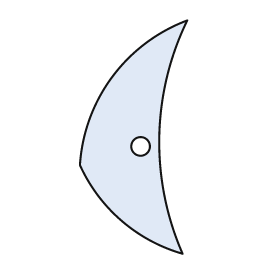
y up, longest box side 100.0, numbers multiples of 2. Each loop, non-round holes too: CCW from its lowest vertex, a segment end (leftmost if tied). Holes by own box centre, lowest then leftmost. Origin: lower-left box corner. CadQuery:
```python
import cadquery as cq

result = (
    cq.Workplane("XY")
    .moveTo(44.0, 0.0)
    .threePointArc((34.0, 50.0), (46.0, 100.0))
    .threePointArc((14.0, 76.0), (0.0, 38.0))
    .threePointArc((18.0, 14.0), (44.0, 0.0))
    .close()
    .moveTo(26.0, 46.0)
    .circle(4.0)
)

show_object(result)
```